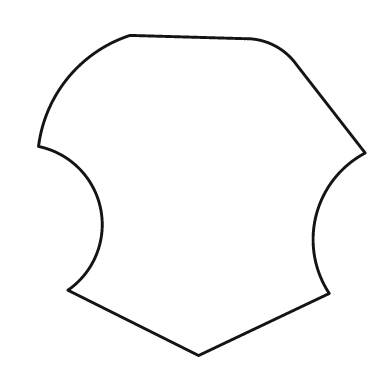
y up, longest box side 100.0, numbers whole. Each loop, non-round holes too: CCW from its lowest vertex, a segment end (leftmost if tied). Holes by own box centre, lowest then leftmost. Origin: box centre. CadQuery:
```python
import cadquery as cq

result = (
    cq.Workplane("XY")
    .moveTo(-1.0, -49.0)
    .lineTo(39.0, -30.0)
    .threePointArc((35.0, -6.0), (50.0, 13.0))
    .lineTo(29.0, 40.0)
    .threePointArc((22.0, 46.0), (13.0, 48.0))
    .lineTo(-22.0, 49.0)
    .threePointArc((-41.0, 36.0), (-50.0, 15.0))
    .threePointArc((-31.0, -4.0), (-41.0, -29.0))
    .close()
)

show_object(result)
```